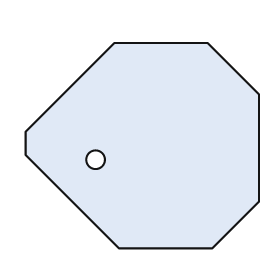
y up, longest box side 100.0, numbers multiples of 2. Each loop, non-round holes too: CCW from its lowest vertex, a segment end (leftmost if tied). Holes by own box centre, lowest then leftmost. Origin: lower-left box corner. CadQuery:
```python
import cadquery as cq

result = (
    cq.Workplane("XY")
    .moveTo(40.0, 0.0)
    .lineTo(80.0, 0.0)
    .lineTo(100.0, 20.0)
    .lineTo(100.0, 66.0)
    .lineTo(78.0, 88.0)
    .lineTo(38.0, 88.0)
    .lineTo(0.0, 50.0)
    .lineTo(0.0, 40.0)
    .close()
    .moveTo(30.0, 38.0)
    .circle(4.0)
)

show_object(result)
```